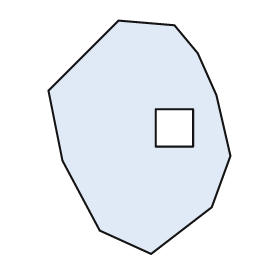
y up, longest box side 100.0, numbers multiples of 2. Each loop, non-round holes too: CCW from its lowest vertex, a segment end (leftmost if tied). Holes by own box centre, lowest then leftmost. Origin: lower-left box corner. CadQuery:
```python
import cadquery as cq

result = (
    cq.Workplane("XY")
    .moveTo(44.0, 0.0)
    .lineTo(70.0, 20.0)
    .lineTo(78.0, 42.0)
    .lineTo(72.0, 68.0)
    .lineTo(64.0, 86.0)
    .lineTo(54.0, 98.0)
    .lineTo(30.0, 100.0)
    .lineTo(0.0, 70.0)
    .lineTo(6.0, 40.0)
    .lineTo(22.0, 10.0)
    .close()
    .moveTo(46.0, 46.0)
    .lineTo(62.0, 46.0)
    .lineTo(62.0, 62.0)
    .lineTo(46.0, 62.0)
    .close()
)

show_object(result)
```